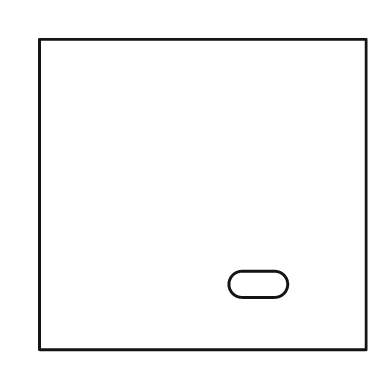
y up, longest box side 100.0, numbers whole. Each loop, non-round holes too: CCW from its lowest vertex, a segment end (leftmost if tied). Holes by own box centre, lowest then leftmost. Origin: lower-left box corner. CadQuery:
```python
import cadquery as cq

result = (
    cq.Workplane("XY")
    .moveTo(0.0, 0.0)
    .lineTo(100.0, 0.0)
    .lineTo(100.0, 95.0)
    .lineTo(0.0, 95.0)
    .close()
    .moveTo(62.0, 16.0)
    .lineTo(72.0, 16.0)
    .threePointArc((76.0, 20.0), (72.0, 24.0))
    .lineTo(62.0, 24.0)
    .threePointArc((58.0, 20.0), (62.0, 16.0))
    .close()
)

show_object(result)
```